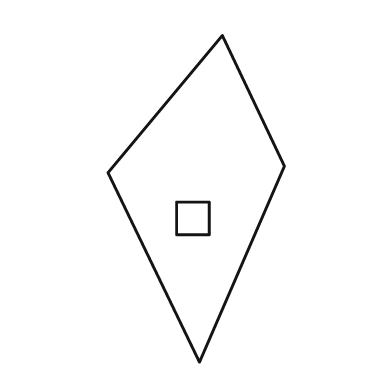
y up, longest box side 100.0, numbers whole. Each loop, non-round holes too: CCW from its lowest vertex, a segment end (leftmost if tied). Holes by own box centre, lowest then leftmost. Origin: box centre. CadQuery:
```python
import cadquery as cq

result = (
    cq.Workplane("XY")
    .moveTo(1.0, -50.0)
    .lineTo(27.0, 10.0)
    .lineTo(8.0, 50.0)
    .lineTo(-27.0, 8.0)
    .close()
    .moveTo(-6.0, -11.0)
    .lineTo(4.0, -11.0)
    .lineTo(4.0, -1.0)
    .lineTo(-6.0, -1.0)
    .close()
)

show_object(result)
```